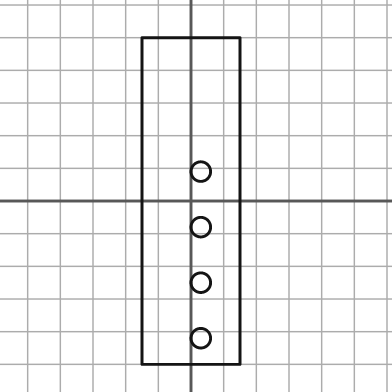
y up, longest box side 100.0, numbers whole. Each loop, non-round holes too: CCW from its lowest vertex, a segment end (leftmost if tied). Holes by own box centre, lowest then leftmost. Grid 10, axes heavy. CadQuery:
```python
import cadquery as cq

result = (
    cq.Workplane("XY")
    .moveTo(-15.0, -50.0)
    .lineTo(15.0, -50.0)
    .lineTo(15.0, 50.0)
    .lineTo(-15.0, 50.0)
    .close()
    .moveTo(3.0, -42.0)
    .circle(3.0)
    .moveTo(3.0, -25.0)
    .circle(3.0)
    .moveTo(3.0, -8.0)
    .circle(3.0)
    .moveTo(3.0, 9.0)
    .circle(3.0)
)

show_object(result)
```